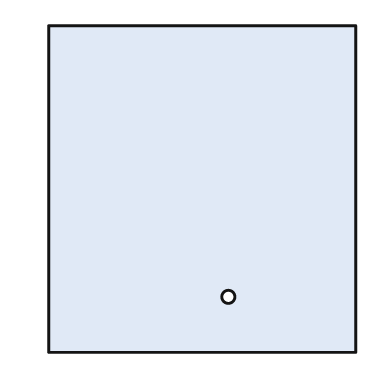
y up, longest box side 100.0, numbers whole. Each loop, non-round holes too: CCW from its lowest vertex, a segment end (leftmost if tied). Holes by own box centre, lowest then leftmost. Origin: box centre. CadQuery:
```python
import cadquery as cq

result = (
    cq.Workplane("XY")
    .moveTo(-47.0, -50.0)
    .lineTo(47.0, -50.0)
    .lineTo(47.0, 50.0)
    .lineTo(-47.0, 50.0)
    .close()
    .moveTo(8.0, -33.0)
    .circle(2.0)
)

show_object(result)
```